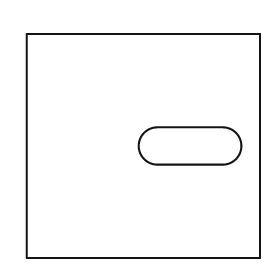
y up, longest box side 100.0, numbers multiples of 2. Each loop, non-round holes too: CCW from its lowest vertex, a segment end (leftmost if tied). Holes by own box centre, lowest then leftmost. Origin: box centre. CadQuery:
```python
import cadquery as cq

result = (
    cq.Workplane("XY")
    .moveTo(-50.0, -48.0)
    .lineTo(50.0, -48.0)
    .lineTo(50.0, 48.0)
    .lineTo(-50.0, 48.0)
    .close()
    .moveTo(6.0, -8.0)
    .lineTo(34.0, -8.0)
    .threePointArc((42.0, 0.0), (34.0, 8.0))
    .lineTo(6.0, 8.0)
    .threePointArc((-2.0, 0.0), (6.0, -8.0))
    .close()
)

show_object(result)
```